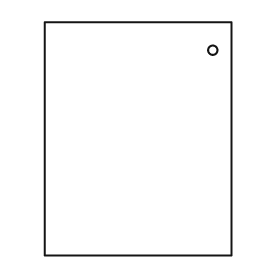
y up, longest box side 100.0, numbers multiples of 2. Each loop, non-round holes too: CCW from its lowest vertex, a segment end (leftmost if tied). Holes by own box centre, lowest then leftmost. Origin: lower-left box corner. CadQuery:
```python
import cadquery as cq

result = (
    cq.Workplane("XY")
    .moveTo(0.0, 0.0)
    .lineTo(80.0, 0.0)
    .lineTo(80.0, 100.0)
    .lineTo(0.0, 100.0)
    .close()
    .moveTo(72.0, 88.0)
    .circle(2.0)
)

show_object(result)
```